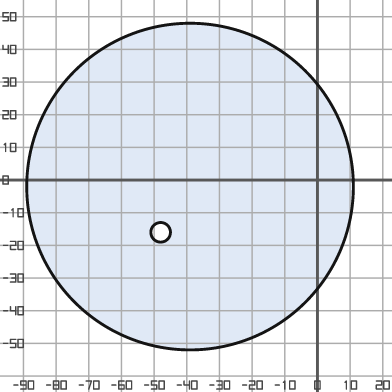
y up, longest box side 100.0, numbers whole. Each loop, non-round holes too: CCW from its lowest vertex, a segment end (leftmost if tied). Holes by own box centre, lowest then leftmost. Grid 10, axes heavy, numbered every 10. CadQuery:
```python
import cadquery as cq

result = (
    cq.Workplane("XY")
    .moveTo(-39.0, -2.0)
    .circle(50.0)
    .moveTo(-48.0, -16.0)
    .circle(3.0)
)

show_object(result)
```